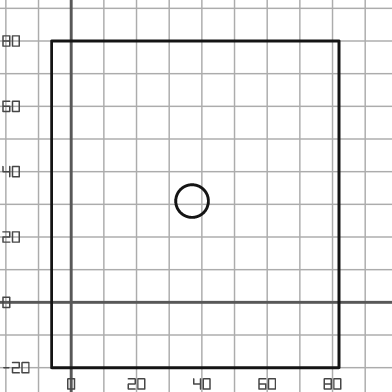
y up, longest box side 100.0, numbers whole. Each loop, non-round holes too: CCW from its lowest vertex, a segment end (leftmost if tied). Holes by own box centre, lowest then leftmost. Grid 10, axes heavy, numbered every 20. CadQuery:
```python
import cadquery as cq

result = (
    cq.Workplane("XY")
    .moveTo(-6.0, -20.0)
    .lineTo(82.0, -20.0)
    .lineTo(82.0, 80.0)
    .lineTo(-6.0, 80.0)
    .close()
    .moveTo(37.0, 31.0)
    .circle(5.0)
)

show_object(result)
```